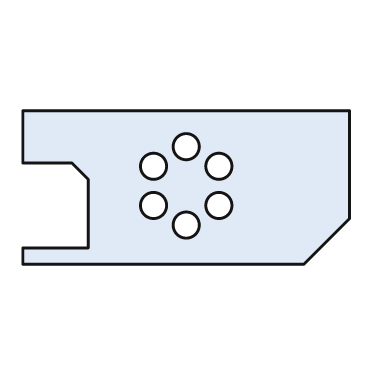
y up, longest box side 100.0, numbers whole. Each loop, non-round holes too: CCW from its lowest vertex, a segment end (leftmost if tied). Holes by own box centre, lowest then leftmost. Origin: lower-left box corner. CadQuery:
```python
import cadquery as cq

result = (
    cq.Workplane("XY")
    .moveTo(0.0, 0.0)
    .lineTo(86.0, 0.0)
    .lineTo(100.0, 14.0)
    .lineTo(100.0, 47.0)
    .lineTo(0.0, 47.0)
    .lineTo(0.0, 31.0)
    .lineTo(15.0, 31.0)
    .lineTo(20.0, 26.0)
    .lineTo(20.0, 5.0)
    .lineTo(0.0, 5.0)
    .close()
    .moveTo(50.0, 12.0)
    .circle(4.0)
    .moveTo(40.0, 18.0)
    .circle(4.0)
    .moveTo(60.0, 18.0)
    .circle(4.0)
    .moveTo(40.0, 30.0)
    .circle(4.0)
    .moveTo(60.0, 30.0)
    .circle(4.0)
    .moveTo(50.0, 36.0)
    .circle(4.0)
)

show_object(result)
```